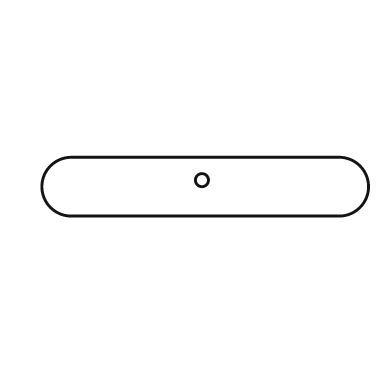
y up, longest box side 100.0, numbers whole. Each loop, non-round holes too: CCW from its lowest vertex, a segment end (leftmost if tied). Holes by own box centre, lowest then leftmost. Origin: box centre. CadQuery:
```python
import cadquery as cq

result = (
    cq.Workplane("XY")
    .moveTo(-41.0, -9.0)
    .lineTo(41.0, -9.0)
    .threePointArc((50.0, 0.0), (41.0, 9.0))
    .lineTo(-41.0, 9.0)
    .threePointArc((-50.0, 0.0), (-41.0, -9.0))
    .close()
    .moveTo(-1.0, 2.0)
    .circle(2.0)
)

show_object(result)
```